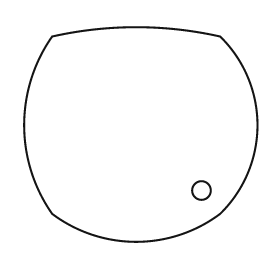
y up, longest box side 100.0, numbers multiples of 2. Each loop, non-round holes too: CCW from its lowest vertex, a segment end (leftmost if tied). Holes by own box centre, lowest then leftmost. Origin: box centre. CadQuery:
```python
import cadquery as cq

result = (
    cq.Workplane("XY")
    .moveTo(-38.0, -34.0)
    .threePointArc((-2.0, -46.0), (34.0, -34.0))
    .threePointArc((50.0, 4.0), (34.0, 42.0))
    .threePointArc((-2.0, 46.0), (-38.0, 42.0))
    .threePointArc((-50.0, 4.0), (-38.0, -34.0))
    .close()
    .moveTo(26.0, -24.0)
    .circle(4.0)
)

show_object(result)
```